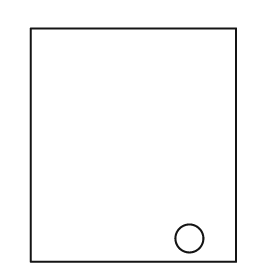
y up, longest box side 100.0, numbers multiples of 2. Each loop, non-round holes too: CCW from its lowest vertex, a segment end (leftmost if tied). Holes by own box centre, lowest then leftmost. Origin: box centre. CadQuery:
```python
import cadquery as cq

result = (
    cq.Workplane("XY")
    .moveTo(-44.0, -50.0)
    .lineTo(44.0, -50.0)
    .lineTo(44.0, 50.0)
    .lineTo(-44.0, 50.0)
    .close()
    .moveTo(24.0, -40.0)
    .circle(6.0)
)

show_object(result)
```